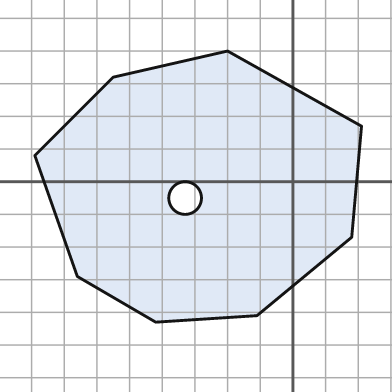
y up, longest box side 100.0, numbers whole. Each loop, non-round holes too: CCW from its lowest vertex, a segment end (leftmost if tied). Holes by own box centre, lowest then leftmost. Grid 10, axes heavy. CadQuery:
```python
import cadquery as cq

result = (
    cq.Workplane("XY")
    .moveTo(-42.0, -43.0)
    .lineTo(-11.0, -41.0)
    .lineTo(18.0, -17.0)
    .lineTo(21.0, 17.0)
    .lineTo(-20.0, 40.0)
    .lineTo(-55.0, 32.0)
    .lineTo(-79.0, 8.0)
    .lineTo(-66.0, -29.0)
    .close()
    .moveTo(-33.0, -5.0)
    .circle(5.0)
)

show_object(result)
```